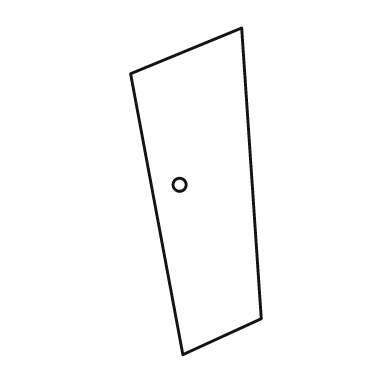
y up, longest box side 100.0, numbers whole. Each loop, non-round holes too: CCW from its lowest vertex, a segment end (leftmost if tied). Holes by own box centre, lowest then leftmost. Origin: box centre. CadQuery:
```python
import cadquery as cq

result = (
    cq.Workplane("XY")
    .moveTo(-4.0, -50.0)
    .lineTo(20.0, -39.0)
    .lineTo(14.0, 50.0)
    .lineTo(-20.0, 36.0)
    .close()
    .moveTo(-5.0, 2.0)
    .circle(2.0)
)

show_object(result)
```